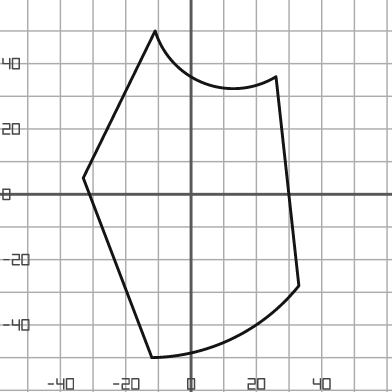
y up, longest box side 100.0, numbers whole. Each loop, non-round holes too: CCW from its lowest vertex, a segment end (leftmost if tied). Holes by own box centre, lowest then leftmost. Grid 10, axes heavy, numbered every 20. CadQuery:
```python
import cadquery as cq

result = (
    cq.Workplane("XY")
    .moveTo(-12.0, -50.0)
    .threePointArc((13.0, -44.0), (33.0, -28.0))
    .lineTo(26.0, 36.0)
    .threePointArc((4.0, 34.0), (-11.0, 50.0))
    .lineTo(-33.0, 5.0)
    .close()
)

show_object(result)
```